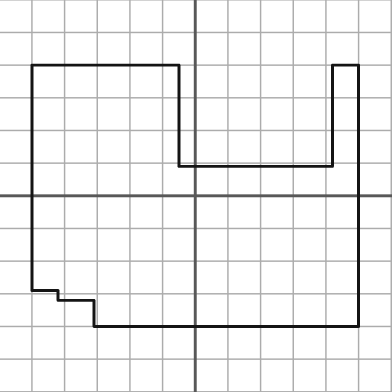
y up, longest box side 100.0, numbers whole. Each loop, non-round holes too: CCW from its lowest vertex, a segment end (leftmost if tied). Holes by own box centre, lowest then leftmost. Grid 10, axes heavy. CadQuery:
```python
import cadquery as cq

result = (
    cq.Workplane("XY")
    .moveTo(-31.0, -40.0)
    .lineTo(50.0, -40.0)
    .lineTo(50.0, 40.0)
    .lineTo(42.0, 40.0)
    .lineTo(42.0, 9.0)
    .lineTo(-5.0, 9.0)
    .lineTo(-5.0, 40.0)
    .lineTo(-50.0, 40.0)
    .lineTo(-50.0, -29.0)
    .lineTo(-42.0, -29.0)
    .lineTo(-42.0, -32.0)
    .lineTo(-31.0, -32.0)
    .close()
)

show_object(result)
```